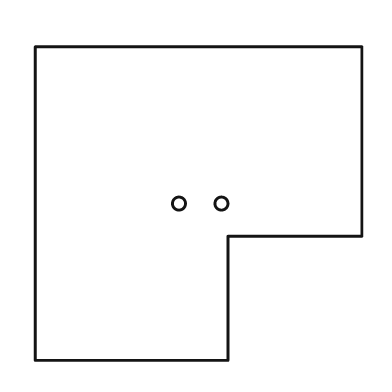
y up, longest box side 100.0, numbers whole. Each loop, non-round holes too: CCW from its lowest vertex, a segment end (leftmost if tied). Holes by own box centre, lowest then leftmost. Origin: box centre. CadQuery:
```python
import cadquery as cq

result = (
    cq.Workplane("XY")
    .moveTo(-50.0, -48.0)
    .lineTo(9.0, -48.0)
    .lineTo(9.0, -10.0)
    .lineTo(50.0, -10.0)
    .lineTo(50.0, 48.0)
    .lineTo(-50.0, 48.0)
    .close()
    .moveTo(-6.0, 0.0)
    .circle(2.0)
    .moveTo(7.0, 0.0)
    .circle(2.0)
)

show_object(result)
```